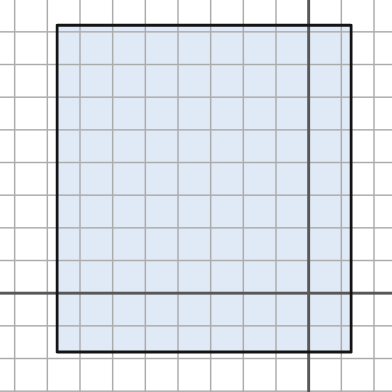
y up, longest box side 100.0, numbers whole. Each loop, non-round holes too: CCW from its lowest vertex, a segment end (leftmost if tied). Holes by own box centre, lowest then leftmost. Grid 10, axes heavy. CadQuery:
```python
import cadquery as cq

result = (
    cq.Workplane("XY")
    .moveTo(-77.0, -18.0)
    .lineTo(13.0, -18.0)
    .lineTo(13.0, 82.0)
    .lineTo(-77.0, 82.0)
    .close()
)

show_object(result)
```